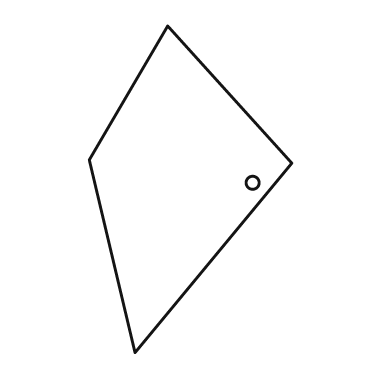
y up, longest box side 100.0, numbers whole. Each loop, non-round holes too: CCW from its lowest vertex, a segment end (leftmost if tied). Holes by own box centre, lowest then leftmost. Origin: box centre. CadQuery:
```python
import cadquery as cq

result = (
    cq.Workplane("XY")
    .moveTo(-17.0, -50.0)
    .lineTo(31.0, 8.0)
    .lineTo(-7.0, 50.0)
    .lineTo(-31.0, 9.0)
    .close()
    .moveTo(19.0, 2.0)
    .circle(2.0)
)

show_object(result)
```